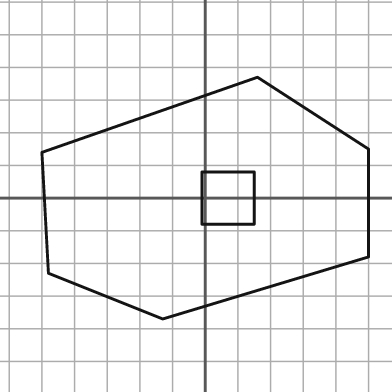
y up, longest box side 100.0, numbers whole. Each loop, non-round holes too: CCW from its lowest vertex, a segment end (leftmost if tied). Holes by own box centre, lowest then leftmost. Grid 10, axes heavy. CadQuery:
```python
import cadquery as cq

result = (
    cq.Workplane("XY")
    .moveTo(-13.0, -37.0)
    .lineTo(50.0, -18.0)
    .lineTo(50.0, 15.0)
    .lineTo(16.0, 37.0)
    .lineTo(-50.0, 14.0)
    .lineTo(-48.0, -23.0)
    .close()
    .moveTo(-1.0, -8.0)
    .lineTo(15.0, -8.0)
    .lineTo(15.0, 8.0)
    .lineTo(-1.0, 8.0)
    .close()
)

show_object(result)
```